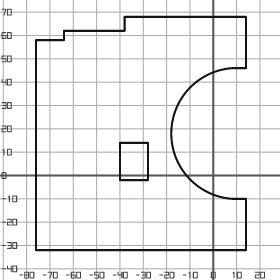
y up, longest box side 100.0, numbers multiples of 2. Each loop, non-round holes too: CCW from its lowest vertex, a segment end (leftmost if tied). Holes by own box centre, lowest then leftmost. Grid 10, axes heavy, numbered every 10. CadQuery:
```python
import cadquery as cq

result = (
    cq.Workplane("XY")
    .moveTo(-76.0, -32.0)
    .lineTo(14.0, -32.0)
    .lineTo(14.0, -10.0)
    .lineTo(8.0, -10.0)
    .threePointArc((-18.0, 18.0), (8.0, 46.0))
    .lineTo(14.0, 46.0)
    .lineTo(14.0, 68.0)
    .lineTo(-38.0, 68.0)
    .lineTo(-38.0, 62.0)
    .lineTo(-64.0, 62.0)
    .lineTo(-64.0, 58.0)
    .lineTo(-76.0, 58.0)
    .close()
    .moveTo(-40.0, -2.0)
    .lineTo(-28.0, -2.0)
    .lineTo(-28.0, 14.0)
    .lineTo(-40.0, 14.0)
    .close()
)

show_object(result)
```